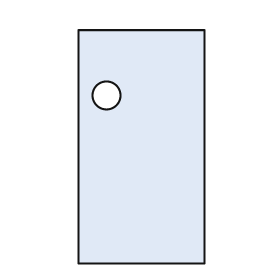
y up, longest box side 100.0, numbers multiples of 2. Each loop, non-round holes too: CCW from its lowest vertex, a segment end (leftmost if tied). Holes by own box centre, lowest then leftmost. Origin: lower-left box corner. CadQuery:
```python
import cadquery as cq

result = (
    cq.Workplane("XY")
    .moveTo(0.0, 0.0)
    .lineTo(54.0, 0.0)
    .lineTo(54.0, 100.0)
    .lineTo(0.0, 100.0)
    .close()
    .moveTo(12.0, 72.0)
    .circle(6.0)
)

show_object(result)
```